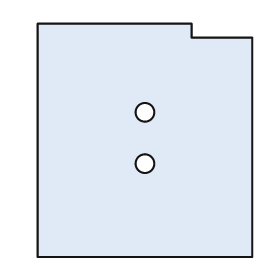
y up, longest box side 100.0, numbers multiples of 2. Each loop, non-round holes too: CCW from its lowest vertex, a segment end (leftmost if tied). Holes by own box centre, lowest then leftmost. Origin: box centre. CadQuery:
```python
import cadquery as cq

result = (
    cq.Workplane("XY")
    .moveTo(-46.0, -50.0)
    .lineTo(46.0, -50.0)
    .lineTo(46.0, 44.0)
    .lineTo(20.0, 44.0)
    .lineTo(20.0, 50.0)
    .lineTo(-46.0, 50.0)
    .close()
    .moveTo(0.0, -10.0)
    .circle(4.0)
    .moveTo(0.0, 12.0)
    .circle(4.0)
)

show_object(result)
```